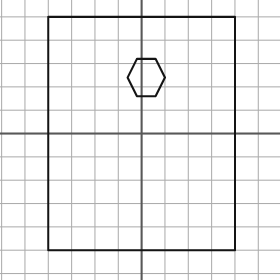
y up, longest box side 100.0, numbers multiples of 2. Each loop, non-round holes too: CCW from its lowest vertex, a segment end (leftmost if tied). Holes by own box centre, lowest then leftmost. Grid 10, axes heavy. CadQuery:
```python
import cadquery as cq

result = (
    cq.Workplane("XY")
    .moveTo(-40.0, -50.0)
    .lineTo(40.0, -50.0)
    .lineTo(40.0, 50.0)
    .lineTo(-40.0, 50.0)
    .close()
    .moveTo(-2.0, 16.0)
    .lineTo(6.0, 16.0)
    .lineTo(10.0, 24.0)
    .lineTo(6.0, 32.0)
    .lineTo(-2.0, 32.0)
    .lineTo(-6.0, 24.0)
    .close()
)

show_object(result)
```